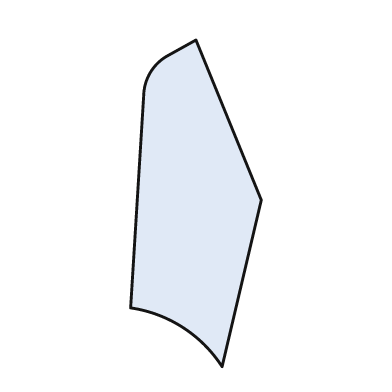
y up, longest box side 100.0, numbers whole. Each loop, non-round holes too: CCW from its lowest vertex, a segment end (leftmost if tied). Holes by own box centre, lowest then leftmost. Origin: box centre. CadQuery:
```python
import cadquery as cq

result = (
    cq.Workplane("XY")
    .moveTo(8.0, -50.0)
    .lineTo(20.0, 1.0)
    .lineTo(0.0, 50.0)
    .lineTo(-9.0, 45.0)
    .threePointArc((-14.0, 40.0), (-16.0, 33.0))
    .lineTo(-20.0, -32.0)
    .threePointArc((-4.0, -38.0), (8.0, -50.0))
    .close()
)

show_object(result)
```